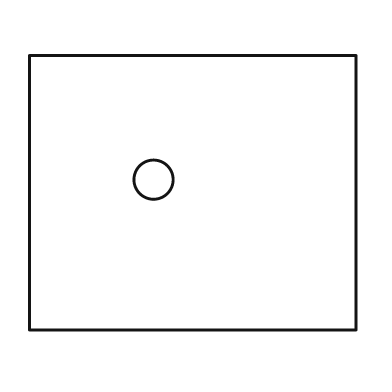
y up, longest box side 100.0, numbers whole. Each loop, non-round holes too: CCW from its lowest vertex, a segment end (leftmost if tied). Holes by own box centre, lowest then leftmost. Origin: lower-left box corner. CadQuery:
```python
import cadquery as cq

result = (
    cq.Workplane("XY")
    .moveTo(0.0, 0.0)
    .lineTo(100.0, 0.0)
    .lineTo(100.0, 84.0)
    .lineTo(0.0, 84.0)
    .close()
    .moveTo(38.0, 46.0)
    .circle(6.0)
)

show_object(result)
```